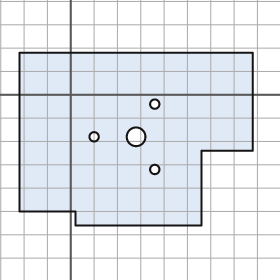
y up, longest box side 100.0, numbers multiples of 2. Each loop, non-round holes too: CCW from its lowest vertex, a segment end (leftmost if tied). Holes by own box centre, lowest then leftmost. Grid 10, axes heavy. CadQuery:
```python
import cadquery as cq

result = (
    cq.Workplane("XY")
    .moveTo(2.0, -56.0)
    .lineTo(56.0, -56.0)
    .lineTo(56.0, -24.0)
    .lineTo(78.0, -24.0)
    .lineTo(78.0, 18.0)
    .lineTo(-22.0, 18.0)
    .lineTo(-22.0, -50.0)
    .lineTo(2.0, -50.0)
    .close()
    .moveTo(36.0, -32.0)
    .circle(2.0)
    .moveTo(10.0, -18.0)
    .circle(2.0)
    .moveTo(28.0, -18.0)
    .circle(4.0)
    .moveTo(36.0, -4.0)
    .circle(2.0)
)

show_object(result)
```